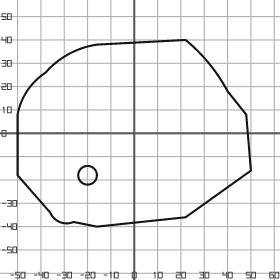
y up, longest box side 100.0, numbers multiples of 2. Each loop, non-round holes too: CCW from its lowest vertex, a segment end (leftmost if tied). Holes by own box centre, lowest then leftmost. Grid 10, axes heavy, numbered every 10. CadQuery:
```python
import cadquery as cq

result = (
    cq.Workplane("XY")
    .moveTo(-16.0, -40.0)
    .lineTo(22.0, -36.0)
    .lineTo(50.0, -16.0)
    .lineTo(48.0, 8.0)
    .lineTo(40.0, 18.0)
    .threePointArc((32.0, 30.0), (22.0, 40.0))
    .lineTo(-16.0, 38.0)
    .threePointArc((-28.0, 34.0), (-38.0, 26.0))
    .threePointArc((-46.0, 18.0), (-50.0, 8.0))
    .lineTo(-50.0, -18.0)
    .lineTo(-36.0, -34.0)
    .threePointArc((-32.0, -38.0), (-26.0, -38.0))
    .close()
    .moveTo(-20.0, -18.0)
    .circle(4.0)
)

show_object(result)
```